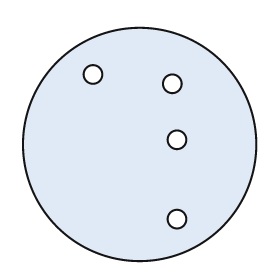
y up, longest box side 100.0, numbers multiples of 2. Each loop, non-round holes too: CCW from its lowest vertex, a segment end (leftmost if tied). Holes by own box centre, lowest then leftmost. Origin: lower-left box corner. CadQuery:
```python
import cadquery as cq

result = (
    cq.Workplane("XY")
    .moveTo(50.0, 50.0)
    .circle(50.0)
    .moveTo(66.0, 18.0)
    .circle(4.0)
    .moveTo(66.0, 52.0)
    .circle(4.0)
    .moveTo(64.0, 76.0)
    .circle(4.0)
    .moveTo(30.0, 80.0)
    .circle(4.0)
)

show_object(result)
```